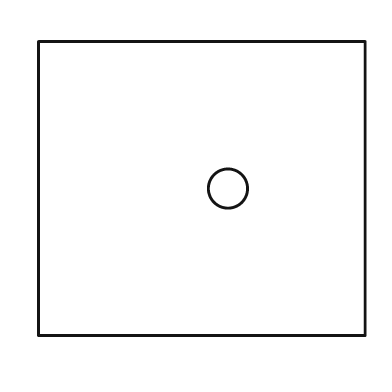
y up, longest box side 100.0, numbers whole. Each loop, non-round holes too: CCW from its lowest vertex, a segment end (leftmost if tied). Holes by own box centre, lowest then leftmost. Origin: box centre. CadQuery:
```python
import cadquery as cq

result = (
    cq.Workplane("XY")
    .moveTo(-50.0, -45.0)
    .lineTo(50.0, -45.0)
    .lineTo(50.0, 45.0)
    .lineTo(-50.0, 45.0)
    .close()
    .moveTo(8.0, 0.0)
    .circle(6.0)
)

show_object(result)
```